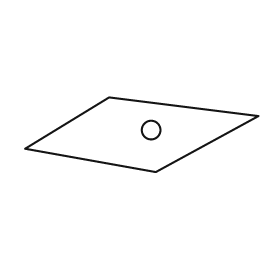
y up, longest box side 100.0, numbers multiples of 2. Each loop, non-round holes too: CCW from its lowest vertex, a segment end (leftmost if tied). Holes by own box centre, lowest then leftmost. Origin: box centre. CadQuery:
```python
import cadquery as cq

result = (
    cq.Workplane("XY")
    .moveTo(6.0, -16.0)
    .lineTo(50.0, 8.0)
    .lineTo(-14.0, 16.0)
    .lineTo(-50.0, -6.0)
    .close()
    .moveTo(4.0, 2.0)
    .circle(4.0)
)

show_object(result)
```